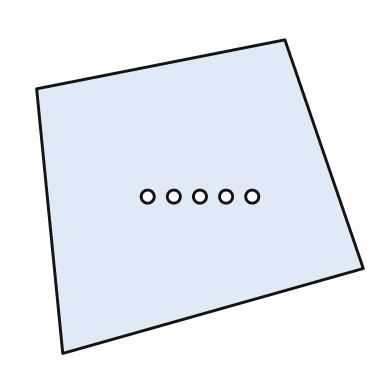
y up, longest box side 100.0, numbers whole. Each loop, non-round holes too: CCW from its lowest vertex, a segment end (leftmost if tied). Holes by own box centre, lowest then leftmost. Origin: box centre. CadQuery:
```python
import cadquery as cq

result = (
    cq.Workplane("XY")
    .moveTo(-42.0, -48.0)
    .lineTo(50.0, -22.0)
    .lineTo(26.0, 48.0)
    .lineTo(-50.0, 33.0)
    .close()
    .moveTo(-16.0, 0.0)
    .circle(2.0)
    .moveTo(-8.0, 0.0)
    .circle(2.0)
    .moveTo(0.0, 0.0)
    .circle(2.0)
    .moveTo(8.0, 0.0)
    .circle(2.0)
    .moveTo(16.0, 0.0)
    .circle(2.0)
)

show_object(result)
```